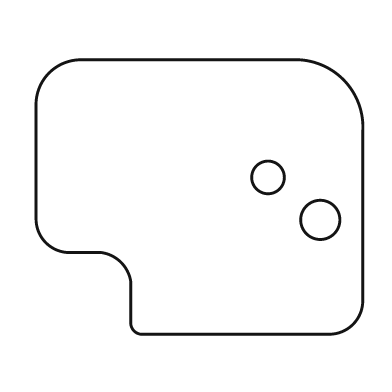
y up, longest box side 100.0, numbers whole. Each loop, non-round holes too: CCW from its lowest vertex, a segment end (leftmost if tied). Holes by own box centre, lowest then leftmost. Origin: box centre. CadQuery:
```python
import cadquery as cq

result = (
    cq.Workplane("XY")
    .moveTo(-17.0, -42.0)
    .lineTo(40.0, -42.0)
    .threePointArc((47.0, -39.0), (50.0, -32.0))
    .lineTo(50.0, 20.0)
    .threePointArc((44.0, 36.0), (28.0, 42.0))
    .lineTo(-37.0, 42.0)
    .threePointArc((-46.0, 38.0), (-50.0, 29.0))
    .lineTo(-50.0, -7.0)
    .threePointArc((-47.0, -14.0), (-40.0, -17.0))
    .lineTo(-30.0, -17.0)
    .threePointArc((-24.0, -20.0), (-21.0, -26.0))
    .lineTo(-21.0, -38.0)
    .threePointArc((-20.0, -41.0), (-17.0, -42.0))
    .close()
    .moveTo(37.0, -7.0)
    .circle(6.0)
    .moveTo(21.0, 6.0)
    .circle(5.0)
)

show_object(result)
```